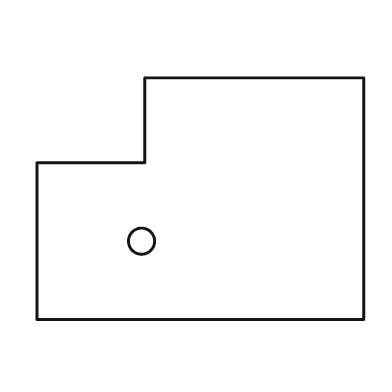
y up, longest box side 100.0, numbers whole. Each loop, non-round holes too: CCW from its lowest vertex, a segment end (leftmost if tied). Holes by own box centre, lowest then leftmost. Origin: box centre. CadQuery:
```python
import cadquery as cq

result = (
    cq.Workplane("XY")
    .moveTo(-50.0, -37.0)
    .lineTo(50.0, -37.0)
    .lineTo(50.0, 37.0)
    .lineTo(-17.0, 37.0)
    .lineTo(-17.0, 11.0)
    .lineTo(-50.0, 11.0)
    .close()
    .moveTo(-18.0, -13.0)
    .circle(4.0)
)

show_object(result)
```